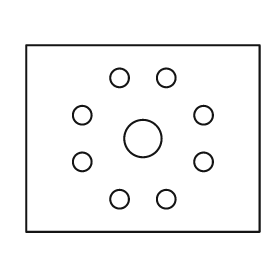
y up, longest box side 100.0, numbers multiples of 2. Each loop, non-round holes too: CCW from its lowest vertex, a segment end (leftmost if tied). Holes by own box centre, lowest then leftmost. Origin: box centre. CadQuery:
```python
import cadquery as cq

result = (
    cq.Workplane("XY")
    .moveTo(-50.0, -40.0)
    .lineTo(50.0, -40.0)
    .lineTo(50.0, 40.0)
    .lineTo(-50.0, 40.0)
    .close()
    .moveTo(-10.0, -26.0)
    .circle(4.0)
    .moveTo(10.0, -26.0)
    .circle(4.0)
    .moveTo(-26.0, -10.0)
    .circle(4.0)
    .moveTo(26.0, -10.0)
    .circle(4.0)
    .moveTo(0.0, 0.0)
    .circle(8.0)
    .moveTo(-26.0, 10.0)
    .circle(4.0)
    .moveTo(26.0, 10.0)
    .circle(4.0)
    .moveTo(-10.0, 26.0)
    .circle(4.0)
    .moveTo(10.0, 26.0)
    .circle(4.0)
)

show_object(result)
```